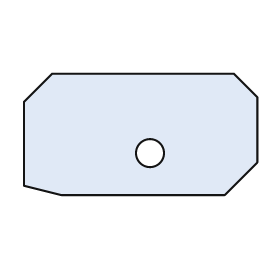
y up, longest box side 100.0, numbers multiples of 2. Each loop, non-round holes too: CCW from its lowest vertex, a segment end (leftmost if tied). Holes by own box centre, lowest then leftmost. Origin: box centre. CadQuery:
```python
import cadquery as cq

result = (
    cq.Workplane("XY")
    .moveTo(-34.0, -26.0)
    .lineTo(36.0, -26.0)
    .lineTo(50.0, -12.0)
    .lineTo(50.0, 16.0)
    .lineTo(40.0, 26.0)
    .lineTo(-38.0, 26.0)
    .lineTo(-50.0, 14.0)
    .lineTo(-50.0, -22.0)
    .close()
    .moveTo(4.0, -8.0)
    .circle(6.0)
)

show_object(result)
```